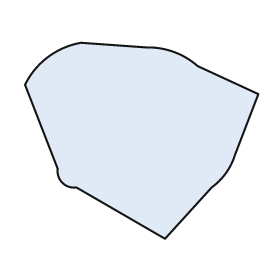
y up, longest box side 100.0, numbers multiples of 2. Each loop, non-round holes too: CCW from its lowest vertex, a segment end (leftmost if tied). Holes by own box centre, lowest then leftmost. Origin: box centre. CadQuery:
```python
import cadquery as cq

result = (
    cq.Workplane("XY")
    .moveTo(10.0, -42.0)
    .lineTo(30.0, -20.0)
    .threePointArc((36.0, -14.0), (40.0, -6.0))
    .lineTo(50.0, 20.0)
    .lineTo(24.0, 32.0)
    .threePointArc((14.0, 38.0), (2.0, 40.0))
    .lineTo(-26.0, 42.0)
    .threePointArc((-40.0, 36.0), (-50.0, 24.0))
    .lineTo(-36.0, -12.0)
    .threePointArc((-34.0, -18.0), (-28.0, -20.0))
    .close()
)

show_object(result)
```